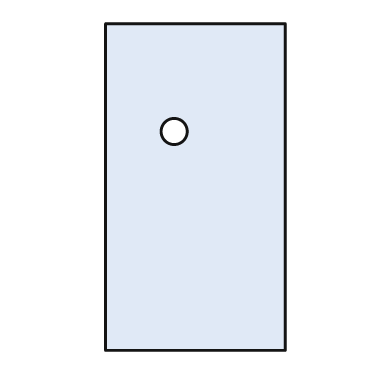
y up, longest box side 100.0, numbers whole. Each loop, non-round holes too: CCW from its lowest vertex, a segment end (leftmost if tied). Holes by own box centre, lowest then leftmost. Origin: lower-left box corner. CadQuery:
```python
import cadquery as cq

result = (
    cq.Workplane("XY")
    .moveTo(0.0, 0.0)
    .lineTo(55.0, 0.0)
    .lineTo(55.0, 100.0)
    .lineTo(0.0, 100.0)
    .close()
    .moveTo(21.0, 67.0)
    .circle(4.0)
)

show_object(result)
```